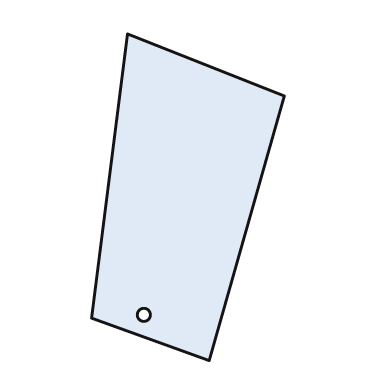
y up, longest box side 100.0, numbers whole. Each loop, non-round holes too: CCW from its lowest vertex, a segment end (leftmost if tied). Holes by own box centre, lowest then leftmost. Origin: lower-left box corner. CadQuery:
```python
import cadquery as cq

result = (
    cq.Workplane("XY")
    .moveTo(36.0, 0.0)
    .lineTo(59.0, 81.0)
    .lineTo(11.0, 100.0)
    .lineTo(0.0, 13.0)
    .close()
    .moveTo(16.0, 14.0)
    .circle(2.0)
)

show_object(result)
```